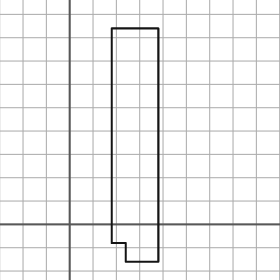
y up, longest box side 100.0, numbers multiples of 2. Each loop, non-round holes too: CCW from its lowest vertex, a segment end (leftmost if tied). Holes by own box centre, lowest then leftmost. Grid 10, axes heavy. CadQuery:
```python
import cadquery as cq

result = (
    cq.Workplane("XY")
    .moveTo(24.0, -16.0)
    .lineTo(38.0, -16.0)
    .lineTo(38.0, 84.0)
    .lineTo(18.0, 84.0)
    .lineTo(18.0, -8.0)
    .lineTo(24.0, -8.0)
    .close()
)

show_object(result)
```